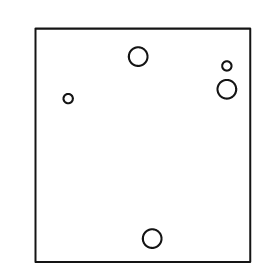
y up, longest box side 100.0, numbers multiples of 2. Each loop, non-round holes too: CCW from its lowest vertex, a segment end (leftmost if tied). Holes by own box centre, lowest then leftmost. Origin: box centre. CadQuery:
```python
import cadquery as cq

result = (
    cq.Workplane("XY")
    .moveTo(-46.0, -50.0)
    .lineTo(46.0, -50.0)
    .lineTo(46.0, 50.0)
    .lineTo(-46.0, 50.0)
    .close()
    .moveTo(4.0, -40.0)
    .circle(4.0)
    .moveTo(-32.0, 20.0)
    .circle(2.0)
    .moveTo(36.0, 24.0)
    .circle(4.0)
    .moveTo(36.0, 34.0)
    .circle(2.0)
    .moveTo(-2.0, 38.0)
    .circle(4.0)
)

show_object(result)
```